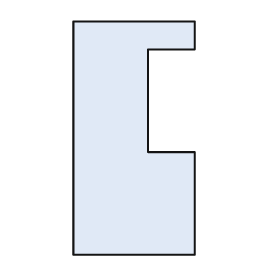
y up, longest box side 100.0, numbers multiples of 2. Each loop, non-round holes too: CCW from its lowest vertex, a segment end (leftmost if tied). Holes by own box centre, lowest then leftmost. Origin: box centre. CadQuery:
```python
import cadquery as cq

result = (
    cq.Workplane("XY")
    .moveTo(-26.0, -50.0)
    .lineTo(26.0, -50.0)
    .lineTo(26.0, -6.0)
    .lineTo(6.0, -6.0)
    .lineTo(6.0, 38.0)
    .lineTo(26.0, 38.0)
    .lineTo(26.0, 50.0)
    .lineTo(-26.0, 50.0)
    .close()
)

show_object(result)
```